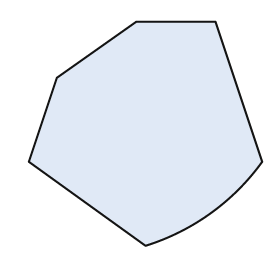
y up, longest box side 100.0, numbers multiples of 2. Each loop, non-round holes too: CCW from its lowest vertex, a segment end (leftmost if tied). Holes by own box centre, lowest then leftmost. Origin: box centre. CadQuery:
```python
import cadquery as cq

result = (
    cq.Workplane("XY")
    .moveTo(0.0, -48.0)
    .threePointArc((28.0, -34.0), (50.0, -12.0))
    .lineTo(30.0, 48.0)
    .lineTo(-4.0, 48.0)
    .lineTo(-38.0, 24.0)
    .lineTo(-50.0, -12.0)
    .close()
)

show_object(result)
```